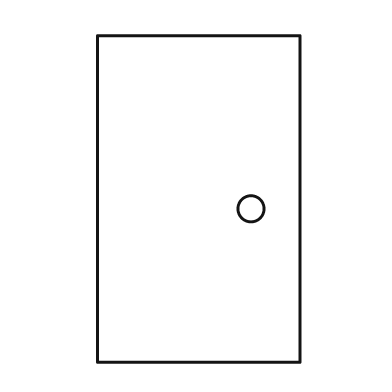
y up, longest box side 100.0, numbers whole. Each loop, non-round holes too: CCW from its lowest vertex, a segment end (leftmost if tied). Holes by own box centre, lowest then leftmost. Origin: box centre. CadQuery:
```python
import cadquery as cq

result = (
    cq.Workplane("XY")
    .moveTo(-31.0, -50.0)
    .lineTo(31.0, -50.0)
    .lineTo(31.0, 50.0)
    .lineTo(-31.0, 50.0)
    .close()
    .moveTo(16.0, -3.0)
    .circle(4.0)
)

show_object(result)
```